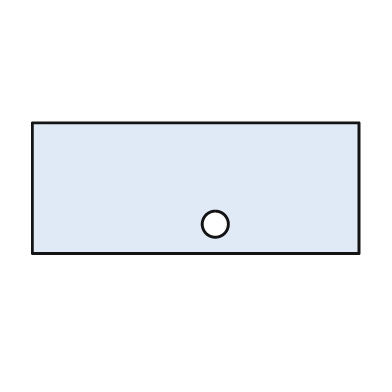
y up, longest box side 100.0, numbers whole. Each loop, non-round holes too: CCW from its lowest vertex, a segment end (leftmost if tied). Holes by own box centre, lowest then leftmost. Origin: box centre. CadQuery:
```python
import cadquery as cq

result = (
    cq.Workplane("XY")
    .moveTo(-50.0, -20.0)
    .lineTo(50.0, -20.0)
    .lineTo(50.0, 20.0)
    .lineTo(-50.0, 20.0)
    .close()
    .moveTo(6.0, -11.0)
    .circle(4.0)
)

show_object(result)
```